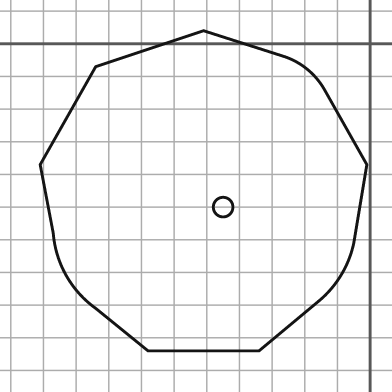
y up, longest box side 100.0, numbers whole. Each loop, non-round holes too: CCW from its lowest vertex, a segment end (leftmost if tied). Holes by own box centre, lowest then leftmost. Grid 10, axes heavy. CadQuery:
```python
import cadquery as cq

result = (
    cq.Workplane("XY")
    .moveTo(-68.0, -94.0)
    .lineTo(-34.0, -94.0)
    .lineTo(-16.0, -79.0)
    .threePointArc((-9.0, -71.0), (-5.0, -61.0))
    .lineTo(-1.0, -37.0)
    .lineTo(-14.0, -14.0)
    .threePointArc((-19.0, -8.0), (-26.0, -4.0))
    .lineTo(-51.0, 4.0)
    .lineTo(-84.0, -7.0)
    .lineTo(-101.0, -37.0)
    .lineTo(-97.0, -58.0)
    .threePointArc((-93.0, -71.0), (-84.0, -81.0))
    .close()
    .moveTo(-45.0, -50.0)
    .circle(3.0)
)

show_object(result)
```